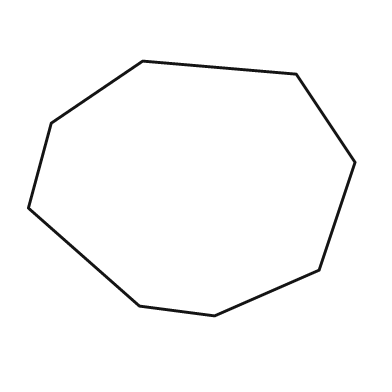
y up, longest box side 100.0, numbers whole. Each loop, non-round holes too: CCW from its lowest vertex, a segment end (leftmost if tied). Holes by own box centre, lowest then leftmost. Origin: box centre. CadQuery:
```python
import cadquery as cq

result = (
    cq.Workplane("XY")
    .moveTo(7.0, -39.0)
    .lineTo(39.0, -25.0)
    .lineTo(50.0, 8.0)
    .lineTo(32.0, 35.0)
    .lineTo(-15.0, 39.0)
    .lineTo(-43.0, 20.0)
    .lineTo(-50.0, -6.0)
    .lineTo(-16.0, -36.0)
    .close()
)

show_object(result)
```